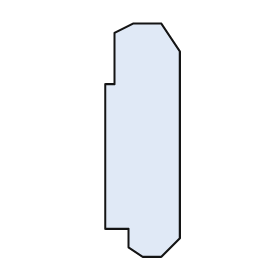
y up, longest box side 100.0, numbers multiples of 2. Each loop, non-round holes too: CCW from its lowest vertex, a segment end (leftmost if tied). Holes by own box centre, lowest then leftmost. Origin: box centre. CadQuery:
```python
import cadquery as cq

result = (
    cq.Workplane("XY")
    .moveTo(0.0, -50.0)
    .lineTo(8.0, -50.0)
    .lineTo(16.0, -42.0)
    .lineTo(16.0, 38.0)
    .lineTo(8.0, 50.0)
    .lineTo(-4.0, 50.0)
    .lineTo(-12.0, 46.0)
    .lineTo(-12.0, 24.0)
    .lineTo(-16.0, 24.0)
    .lineTo(-16.0, -38.0)
    .lineTo(-6.0, -38.0)
    .lineTo(-6.0, -46.0)
    .close()
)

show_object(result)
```